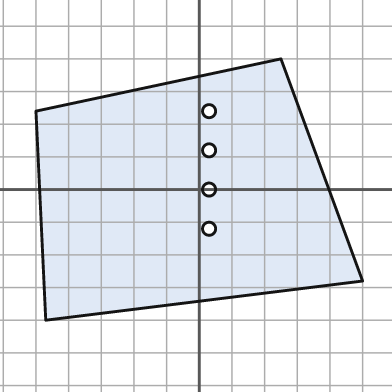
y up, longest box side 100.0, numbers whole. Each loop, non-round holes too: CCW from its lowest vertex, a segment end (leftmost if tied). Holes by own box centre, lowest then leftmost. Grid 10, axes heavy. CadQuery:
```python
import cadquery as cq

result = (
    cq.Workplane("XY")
    .moveTo(-47.0, -40.0)
    .lineTo(50.0, -28.0)
    .lineTo(25.0, 40.0)
    .lineTo(-50.0, 24.0)
    .close()
    .moveTo(3.0, -12.0)
    .circle(2.0)
    .moveTo(3.0, 0.0)
    .circle(2.0)
    .moveTo(3.0, 12.0)
    .circle(2.0)
    .moveTo(3.0, 24.0)
    .circle(2.0)
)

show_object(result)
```